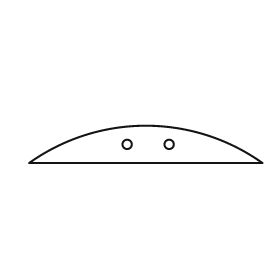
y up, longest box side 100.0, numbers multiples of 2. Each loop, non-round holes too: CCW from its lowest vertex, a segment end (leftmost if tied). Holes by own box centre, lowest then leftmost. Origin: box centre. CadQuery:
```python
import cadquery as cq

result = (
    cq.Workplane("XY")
    .moveTo(-50.0, -8.0)
    .lineTo(50.0, -8.0)
    .threePointArc((0.0, 8.0), (-50.0, -8.0))
    .close()
    .moveTo(-8.0, 0.0)
    .circle(2.0)
    .moveTo(10.0, 0.0)
    .circle(2.0)
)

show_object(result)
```